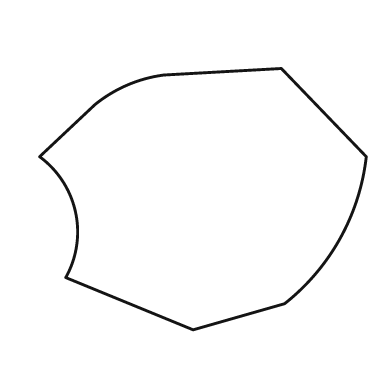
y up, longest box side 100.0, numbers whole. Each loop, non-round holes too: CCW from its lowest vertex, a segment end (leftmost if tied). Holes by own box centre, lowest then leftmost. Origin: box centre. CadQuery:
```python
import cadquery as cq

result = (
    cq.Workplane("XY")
    .moveTo(-3.0, -40.0)
    .lineTo(25.0, -32.0)
    .threePointArc((42.0, -12.0), (50.0, 13.0))
    .lineTo(24.0, 40.0)
    .lineTo(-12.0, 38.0)
    .threePointArc((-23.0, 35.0), (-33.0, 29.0))
    .lineTo(-50.0, 13.0)
    .threePointArc((-39.0, -4.0), (-42.0, -24.0))
    .close()
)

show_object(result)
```